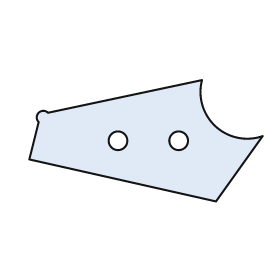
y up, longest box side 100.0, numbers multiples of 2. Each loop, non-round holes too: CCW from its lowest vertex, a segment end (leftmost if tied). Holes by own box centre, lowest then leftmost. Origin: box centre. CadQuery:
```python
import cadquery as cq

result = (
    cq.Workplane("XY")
    .moveTo(30.0, -26.0)
    .lineTo(50.0, 2.0)
    .threePointArc((30.0, 6.0), (24.0, 26.0))
    .lineTo(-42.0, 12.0)
    .threePointArc((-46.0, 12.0), (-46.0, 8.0))
    .lineTo(-50.0, -8.0)
    .close()
    .moveTo(-12.0, 0.0)
    .circle(4.0)
    .moveTo(14.0, 0.0)
    .circle(4.0)
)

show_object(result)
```